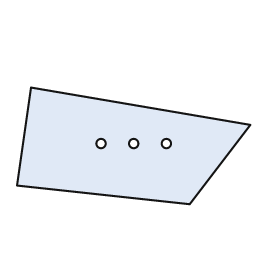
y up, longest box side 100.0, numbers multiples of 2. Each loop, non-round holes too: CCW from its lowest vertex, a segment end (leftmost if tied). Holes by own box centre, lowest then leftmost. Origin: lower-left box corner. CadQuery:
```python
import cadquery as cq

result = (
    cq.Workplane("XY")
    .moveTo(74.0, 0.0)
    .lineTo(100.0, 34.0)
    .lineTo(6.0, 50.0)
    .lineTo(0.0, 8.0)
    .close()
    .moveTo(36.0, 26.0)
    .circle(2.0)
    .moveTo(50.0, 26.0)
    .circle(2.0)
    .moveTo(64.0, 26.0)
    .circle(2.0)
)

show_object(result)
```